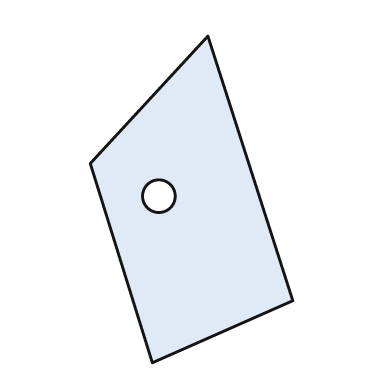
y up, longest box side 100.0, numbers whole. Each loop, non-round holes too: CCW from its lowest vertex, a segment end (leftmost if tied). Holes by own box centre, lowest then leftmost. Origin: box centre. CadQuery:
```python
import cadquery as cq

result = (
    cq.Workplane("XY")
    .moveTo(-12.0, -50.0)
    .lineTo(31.0, -31.0)
    .lineTo(5.0, 50.0)
    .lineTo(-31.0, 11.0)
    .close()
    .moveTo(-10.0, 1.0)
    .circle(5.0)
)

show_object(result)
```